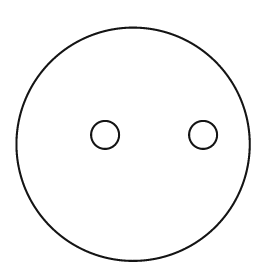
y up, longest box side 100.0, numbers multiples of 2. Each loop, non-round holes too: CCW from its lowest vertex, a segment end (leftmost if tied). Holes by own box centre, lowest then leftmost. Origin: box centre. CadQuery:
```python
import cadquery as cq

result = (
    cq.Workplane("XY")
    .moveTo(0.0, 0.0)
    .circle(50.0)
    .moveTo(-12.0, 4.0)
    .circle(6.0)
    .moveTo(30.0, 4.0)
    .circle(6.0)
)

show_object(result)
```